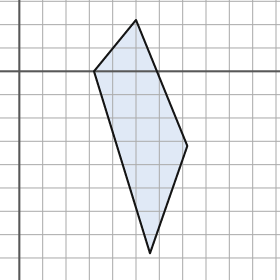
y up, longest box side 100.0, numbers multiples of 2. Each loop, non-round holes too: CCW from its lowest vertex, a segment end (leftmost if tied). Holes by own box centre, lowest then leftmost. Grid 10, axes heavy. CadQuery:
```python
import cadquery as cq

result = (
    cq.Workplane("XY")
    .moveTo(56.0, -78.0)
    .lineTo(72.0, -32.0)
    .lineTo(50.0, 22.0)
    .lineTo(32.0, 0.0)
    .close()
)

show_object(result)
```